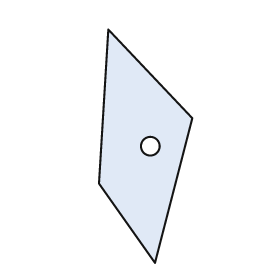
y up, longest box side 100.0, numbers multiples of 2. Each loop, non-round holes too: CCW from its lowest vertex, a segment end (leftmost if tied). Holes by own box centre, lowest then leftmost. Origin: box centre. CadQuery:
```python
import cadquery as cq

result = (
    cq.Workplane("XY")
    .moveTo(4.0, -50.0)
    .lineTo(20.0, 12.0)
    .lineTo(-16.0, 50.0)
    .lineTo(-20.0, -16.0)
    .close()
    .moveTo(2.0, 0.0)
    .circle(4.0)
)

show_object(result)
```